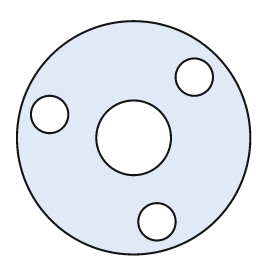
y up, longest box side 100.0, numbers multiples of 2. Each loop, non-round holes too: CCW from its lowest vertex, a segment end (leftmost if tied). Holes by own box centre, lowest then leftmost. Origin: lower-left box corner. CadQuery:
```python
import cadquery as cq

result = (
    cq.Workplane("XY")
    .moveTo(50.0, 50.0)
    .circle(50.0)
    .moveTo(60.0, 14.0)
    .circle(8.0)
    .moveTo(50.0, 50.0)
    .circle(16.0)
    .moveTo(14.0, 60.0)
    .circle(8.0)
    .moveTo(76.0, 76.0)
    .circle(8.0)
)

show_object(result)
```